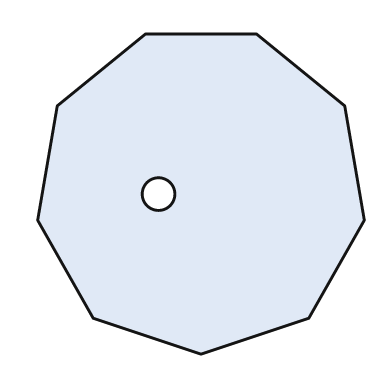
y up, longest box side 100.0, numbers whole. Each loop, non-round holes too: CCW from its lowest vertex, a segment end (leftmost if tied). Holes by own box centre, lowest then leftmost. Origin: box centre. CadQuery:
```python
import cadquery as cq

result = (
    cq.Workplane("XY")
    .moveTo(0.0, -49.0)
    .lineTo(33.0, -38.0)
    .lineTo(50.0, -8.0)
    .lineTo(44.0, 27.0)
    .lineTo(17.0, 49.0)
    .lineTo(-17.0, 49.0)
    .lineTo(-44.0, 27.0)
    .lineTo(-50.0, -8.0)
    .lineTo(-33.0, -38.0)
    .close()
    .moveTo(-13.0, 0.0)
    .circle(5.0)
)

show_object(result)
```